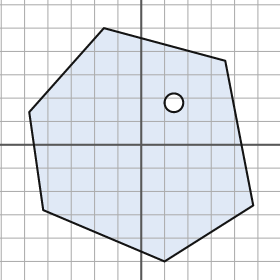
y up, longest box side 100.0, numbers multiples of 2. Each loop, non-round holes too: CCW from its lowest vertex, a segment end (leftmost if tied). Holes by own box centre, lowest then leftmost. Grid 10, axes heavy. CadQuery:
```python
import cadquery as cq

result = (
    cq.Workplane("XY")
    .moveTo(10.0, -50.0)
    .lineTo(48.0, -26.0)
    .lineTo(36.0, 36.0)
    .lineTo(-16.0, 50.0)
    .lineTo(-48.0, 14.0)
    .lineTo(-42.0, -28.0)
    .close()
    .moveTo(14.0, 18.0)
    .circle(4.0)
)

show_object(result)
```